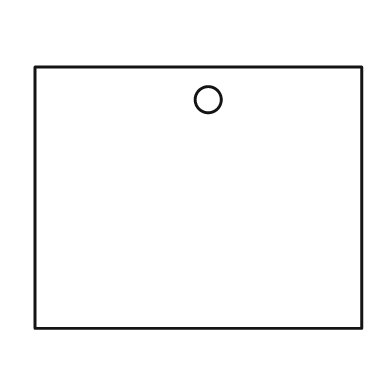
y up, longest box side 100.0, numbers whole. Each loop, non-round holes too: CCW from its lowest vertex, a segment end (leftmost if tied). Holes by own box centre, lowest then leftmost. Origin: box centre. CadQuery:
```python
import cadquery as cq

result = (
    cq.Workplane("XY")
    .moveTo(-50.0, -40.0)
    .lineTo(50.0, -40.0)
    .lineTo(50.0, 40.0)
    .lineTo(-50.0, 40.0)
    .close()
    .moveTo(3.0, 30.0)
    .circle(4.0)
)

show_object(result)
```